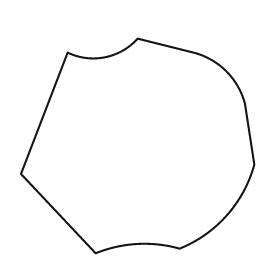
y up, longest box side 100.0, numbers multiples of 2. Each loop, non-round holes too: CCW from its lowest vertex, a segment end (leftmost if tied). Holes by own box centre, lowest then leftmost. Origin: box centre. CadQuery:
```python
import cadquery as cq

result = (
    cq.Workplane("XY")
    .moveTo(-18.0, -46.0)
    .threePointArc((0.0, -42.0), (18.0, -44.0))
    .threePointArc((38.0, -30.0), (50.0, -8.0))
    .lineTo(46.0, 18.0)
    .threePointArc((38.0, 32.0), (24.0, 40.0))
    .lineTo(0.0, 46.0)
    .threePointArc((-14.0, 38.0), (-30.0, 40.0))
    .lineTo(-50.0, -12.0)
    .close()
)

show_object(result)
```